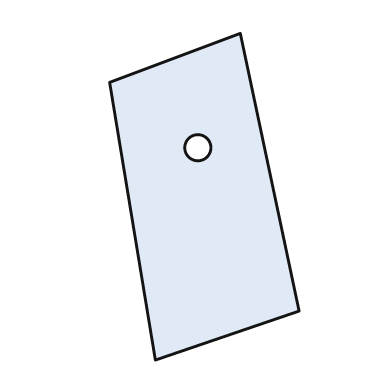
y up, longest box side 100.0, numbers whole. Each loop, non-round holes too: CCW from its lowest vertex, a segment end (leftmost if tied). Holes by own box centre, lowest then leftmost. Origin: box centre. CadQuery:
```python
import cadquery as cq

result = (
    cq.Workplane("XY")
    .moveTo(-15.0, -50.0)
    .lineTo(29.0, -35.0)
    .lineTo(11.0, 50.0)
    .lineTo(-29.0, 35.0)
    .close()
    .moveTo(-2.0, 15.0)
    .circle(4.0)
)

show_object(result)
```